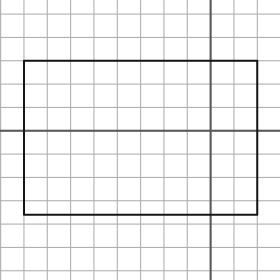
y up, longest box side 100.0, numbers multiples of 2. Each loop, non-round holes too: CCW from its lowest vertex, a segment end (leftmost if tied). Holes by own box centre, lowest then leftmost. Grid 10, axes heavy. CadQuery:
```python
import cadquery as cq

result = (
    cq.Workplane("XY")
    .moveTo(-80.0, -36.0)
    .lineTo(20.0, -36.0)
    .lineTo(20.0, 30.0)
    .lineTo(-80.0, 30.0)
    .close()
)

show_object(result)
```